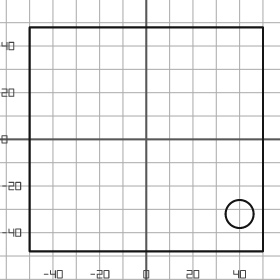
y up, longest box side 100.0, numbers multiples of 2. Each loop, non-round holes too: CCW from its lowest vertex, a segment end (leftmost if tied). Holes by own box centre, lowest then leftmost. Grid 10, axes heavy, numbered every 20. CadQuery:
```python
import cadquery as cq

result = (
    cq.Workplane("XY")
    .moveTo(-50.0, -48.0)
    .lineTo(50.0, -48.0)
    .lineTo(50.0, 48.0)
    .lineTo(-50.0, 48.0)
    .close()
    .moveTo(40.0, -32.0)
    .circle(6.0)
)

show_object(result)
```